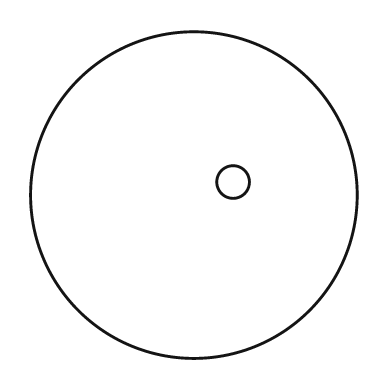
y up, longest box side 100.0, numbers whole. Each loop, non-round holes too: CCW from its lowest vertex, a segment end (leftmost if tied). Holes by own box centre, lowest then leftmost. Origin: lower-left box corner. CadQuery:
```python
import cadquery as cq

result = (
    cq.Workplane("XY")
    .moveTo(50.0, 50.0)
    .circle(50.0)
    .moveTo(62.0, 54.0)
    .circle(5.0)
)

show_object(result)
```